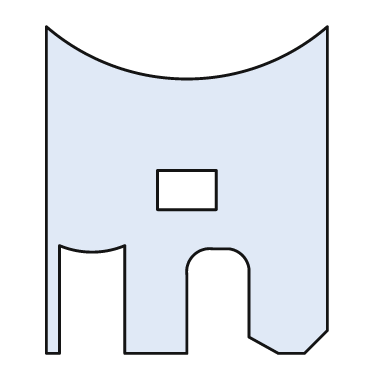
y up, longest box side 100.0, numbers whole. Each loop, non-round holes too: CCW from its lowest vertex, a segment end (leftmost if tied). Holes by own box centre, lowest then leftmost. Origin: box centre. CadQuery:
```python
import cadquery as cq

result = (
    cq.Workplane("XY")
    .moveTo(-43.0, -50.0)
    .lineTo(-39.0, -50.0)
    .lineTo(-39.0, -17.0)
    .threePointArc((-29.0, -19.0), (-19.0, -17.0))
    .lineTo(-19.0, -50.0)
    .lineTo(0.0, -50.0)
    .lineTo(0.0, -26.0)
    .threePointArc((2.0, -20.0), (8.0, -18.0))
    .lineTo(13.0, -18.0)
    .threePointArc((17.0, -20.0), (19.0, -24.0))
    .lineTo(19.0, -45.0)
    .lineTo(28.0, -50.0)
    .lineTo(36.0, -50.0)
    .lineTo(43.0, -43.0)
    .lineTo(43.0, 50.0)
    .threePointArc((0.0, 34.0), (-43.0, 50.0))
    .close()
    .moveTo(-9.0, -6.0)
    .lineTo(9.0, -6.0)
    .lineTo(9.0, 6.0)
    .lineTo(-9.0, 6.0)
    .close()
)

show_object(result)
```